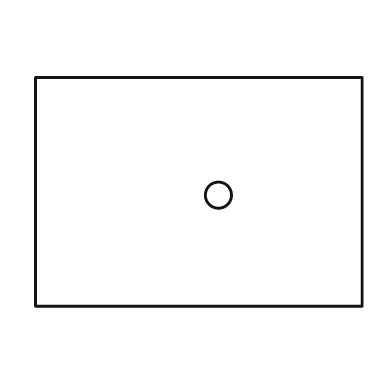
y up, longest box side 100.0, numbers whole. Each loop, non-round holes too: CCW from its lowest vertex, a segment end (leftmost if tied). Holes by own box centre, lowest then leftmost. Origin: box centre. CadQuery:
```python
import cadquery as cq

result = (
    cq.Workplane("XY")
    .moveTo(-50.0, -35.0)
    .lineTo(50.0, -35.0)
    .lineTo(50.0, 35.0)
    .lineTo(-50.0, 35.0)
    .close()
    .moveTo(6.0, -1.0)
    .circle(4.0)
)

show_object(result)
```